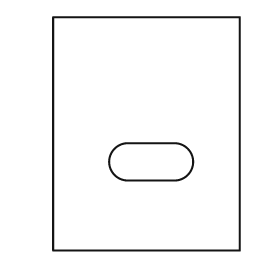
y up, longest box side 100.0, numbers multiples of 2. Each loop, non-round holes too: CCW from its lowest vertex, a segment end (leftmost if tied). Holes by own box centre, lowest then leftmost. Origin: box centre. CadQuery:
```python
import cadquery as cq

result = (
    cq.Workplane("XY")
    .moveTo(-40.0, -50.0)
    .lineTo(40.0, -50.0)
    .lineTo(40.0, 50.0)
    .lineTo(-40.0, 50.0)
    .close()
    .moveTo(-8.0, -20.0)
    .lineTo(12.0, -20.0)
    .threePointArc((20.0, -12.0), (12.0, -4.0))
    .lineTo(-8.0, -4.0)
    .threePointArc((-16.0, -12.0), (-8.0, -20.0))
    .close()
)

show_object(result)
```